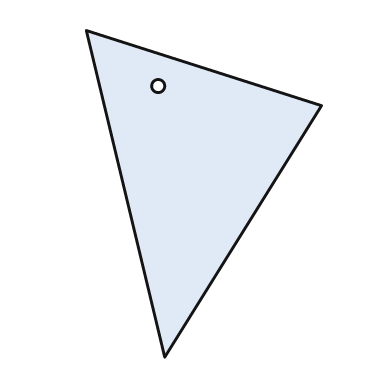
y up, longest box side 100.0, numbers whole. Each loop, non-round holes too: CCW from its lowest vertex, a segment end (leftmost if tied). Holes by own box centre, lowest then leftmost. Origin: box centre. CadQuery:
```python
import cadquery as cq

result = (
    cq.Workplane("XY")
    .moveTo(-12.0, -50.0)
    .lineTo(36.0, 27.0)
    .lineTo(-36.0, 50.0)
    .close()
    .moveTo(-14.0, 33.0)
    .circle(2.0)
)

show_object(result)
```